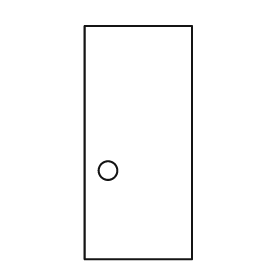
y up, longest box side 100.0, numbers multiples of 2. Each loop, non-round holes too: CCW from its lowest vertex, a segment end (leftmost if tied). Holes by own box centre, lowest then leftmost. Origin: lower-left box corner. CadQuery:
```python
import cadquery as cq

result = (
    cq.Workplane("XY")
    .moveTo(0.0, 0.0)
    .lineTo(46.0, 0.0)
    .lineTo(46.0, 100.0)
    .lineTo(0.0, 100.0)
    .close()
    .moveTo(10.0, 38.0)
    .circle(4.0)
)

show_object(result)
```